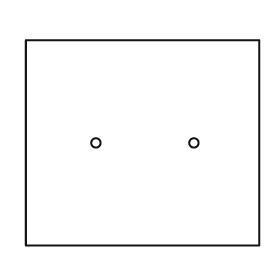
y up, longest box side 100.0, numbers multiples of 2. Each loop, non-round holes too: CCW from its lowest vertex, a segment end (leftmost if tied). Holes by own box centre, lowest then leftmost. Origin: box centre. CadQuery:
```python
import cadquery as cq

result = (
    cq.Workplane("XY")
    .moveTo(-50.0, -44.0)
    .lineTo(50.0, -44.0)
    .lineTo(50.0, 44.0)
    .lineTo(-50.0, 44.0)
    .close()
    .moveTo(-20.0, 0.0)
    .circle(2.0)
    .moveTo(22.0, 0.0)
    .circle(2.0)
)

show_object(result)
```